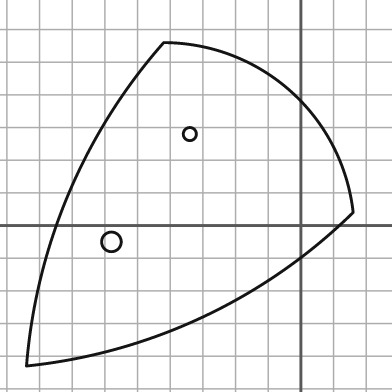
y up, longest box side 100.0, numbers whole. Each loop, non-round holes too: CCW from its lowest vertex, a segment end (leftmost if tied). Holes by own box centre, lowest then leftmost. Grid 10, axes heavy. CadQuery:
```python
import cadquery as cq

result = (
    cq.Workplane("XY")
    .moveTo(-84.0, -43.0)
    .threePointArc((-30.0, -28.0), (16.0, 4.0))
    .threePointArc((-3.0, 41.0), (-42.0, 56.0))
    .threePointArc((-71.0, 10.0), (-84.0, -43.0))
    .close()
    .moveTo(-58.0, -5.0)
    .circle(3.0)
    .moveTo(-34.0, 28.0)
    .circle(2.0)
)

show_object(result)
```